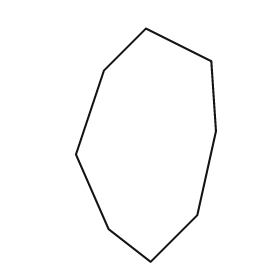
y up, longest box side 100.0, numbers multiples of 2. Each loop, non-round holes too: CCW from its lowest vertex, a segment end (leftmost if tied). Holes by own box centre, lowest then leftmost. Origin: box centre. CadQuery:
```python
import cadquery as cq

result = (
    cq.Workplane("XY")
    .moveTo(2.0, -50.0)
    .lineTo(22.0, -30.0)
    .lineTo(30.0, 6.0)
    .lineTo(28.0, 36.0)
    .lineTo(0.0, 50.0)
    .lineTo(-18.0, 32.0)
    .lineTo(-30.0, -4.0)
    .lineTo(-16.0, -36.0)
    .close()
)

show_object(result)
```